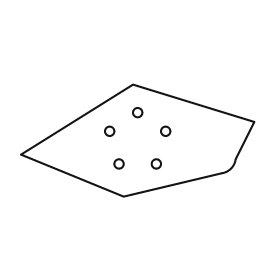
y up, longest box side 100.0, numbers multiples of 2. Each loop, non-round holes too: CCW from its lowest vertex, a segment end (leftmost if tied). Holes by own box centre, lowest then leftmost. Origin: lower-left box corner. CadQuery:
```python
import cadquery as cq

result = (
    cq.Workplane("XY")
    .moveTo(44.0, 0.0)
    .lineTo(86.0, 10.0)
    .threePointArc((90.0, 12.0), (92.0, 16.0))
    .lineTo(100.0, 32.0)
    .lineTo(48.0, 48.0)
    .lineTo(0.0, 18.0)
    .close()
    .moveTo(42.0, 14.0)
    .circle(2.0)
    .moveTo(58.0, 14.0)
    .circle(2.0)
    .moveTo(38.0, 28.0)
    .circle(2.0)
    .moveTo(62.0, 28.0)
    .circle(2.0)
    .moveTo(50.0, 36.0)
    .circle(2.0)
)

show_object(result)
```